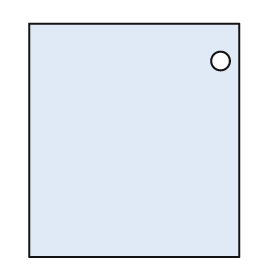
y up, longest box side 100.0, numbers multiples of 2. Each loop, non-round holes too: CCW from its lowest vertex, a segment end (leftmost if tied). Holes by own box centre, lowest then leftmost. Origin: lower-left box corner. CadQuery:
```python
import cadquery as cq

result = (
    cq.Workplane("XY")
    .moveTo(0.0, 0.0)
    .lineTo(90.0, 0.0)
    .lineTo(90.0, 100.0)
    .lineTo(0.0, 100.0)
    .close()
    .moveTo(82.0, 84.0)
    .circle(4.0)
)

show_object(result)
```